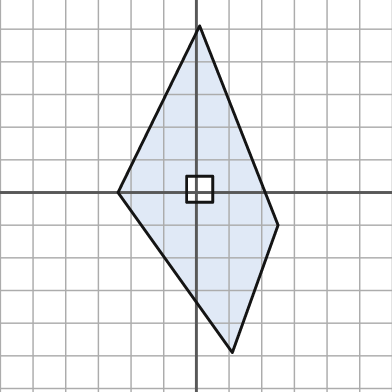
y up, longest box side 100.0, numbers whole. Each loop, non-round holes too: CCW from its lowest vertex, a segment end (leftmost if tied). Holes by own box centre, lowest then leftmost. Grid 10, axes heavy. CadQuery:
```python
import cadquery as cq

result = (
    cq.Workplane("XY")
    .moveTo(11.0, -49.0)
    .lineTo(25.0, -10.0)
    .lineTo(1.0, 51.0)
    .lineTo(-24.0, 0.0)
    .close()
    .moveTo(-3.0, -3.0)
    .lineTo(5.0, -3.0)
    .lineTo(5.0, 5.0)
    .lineTo(-3.0, 5.0)
    .close()
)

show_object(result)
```